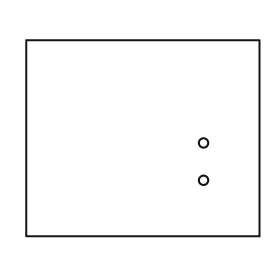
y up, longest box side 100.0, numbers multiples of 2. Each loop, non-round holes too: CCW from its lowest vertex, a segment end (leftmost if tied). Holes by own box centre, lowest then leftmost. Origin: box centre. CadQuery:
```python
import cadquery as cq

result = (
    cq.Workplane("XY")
    .moveTo(-50.0, -42.0)
    .lineTo(50.0, -42.0)
    .lineTo(50.0, 42.0)
    .lineTo(-50.0, 42.0)
    .close()
    .moveTo(26.0, -18.0)
    .circle(2.0)
    .moveTo(26.0, -2.0)
    .circle(2.0)
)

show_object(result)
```